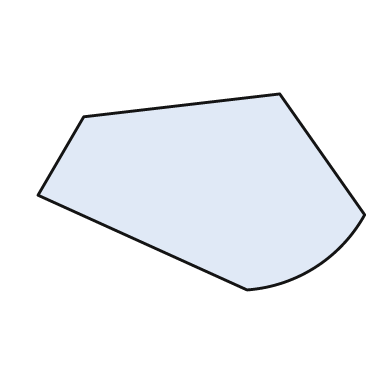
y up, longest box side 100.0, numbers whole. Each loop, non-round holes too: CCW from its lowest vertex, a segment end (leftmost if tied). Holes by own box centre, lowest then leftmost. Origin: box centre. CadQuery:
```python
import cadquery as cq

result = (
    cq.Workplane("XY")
    .moveTo(14.0, -30.0)
    .threePointArc((35.0, -23.0), (50.0, -7.0))
    .lineTo(24.0, 30.0)
    .lineTo(-36.0, 23.0)
    .lineTo(-50.0, -1.0)
    .close()
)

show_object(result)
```